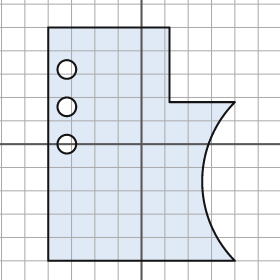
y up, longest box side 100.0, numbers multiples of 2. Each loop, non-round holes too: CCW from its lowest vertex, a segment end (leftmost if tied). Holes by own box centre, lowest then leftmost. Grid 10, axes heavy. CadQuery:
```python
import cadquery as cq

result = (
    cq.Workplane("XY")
    .moveTo(-40.0, -50.0)
    .lineTo(40.0, -50.0)
    .threePointArc((26.0, -16.0), (40.0, 18.0))
    .lineTo(12.0, 18.0)
    .lineTo(12.0, 50.0)
    .lineTo(-40.0, 50.0)
    .close()
    .moveTo(-32.0, 0.0)
    .circle(4.0)
    .moveTo(-32.0, 16.0)
    .circle(4.0)
    .moveTo(-32.0, 32.0)
    .circle(4.0)
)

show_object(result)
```